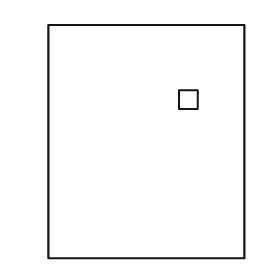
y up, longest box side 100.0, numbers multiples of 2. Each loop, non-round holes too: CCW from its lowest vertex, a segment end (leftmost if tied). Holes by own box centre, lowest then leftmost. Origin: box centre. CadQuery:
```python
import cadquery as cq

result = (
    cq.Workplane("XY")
    .moveTo(-42.0, -50.0)
    .lineTo(42.0, -50.0)
    .lineTo(42.0, 50.0)
    .lineTo(-42.0, 50.0)
    .close()
    .moveTo(14.0, 14.0)
    .lineTo(22.0, 14.0)
    .lineTo(22.0, 22.0)
    .lineTo(14.0, 22.0)
    .close()
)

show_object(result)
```